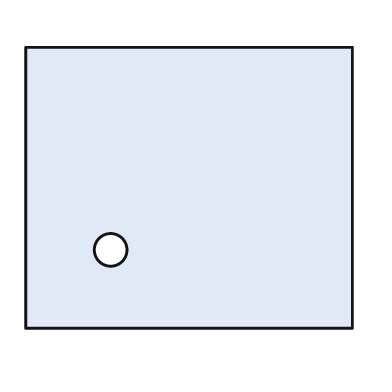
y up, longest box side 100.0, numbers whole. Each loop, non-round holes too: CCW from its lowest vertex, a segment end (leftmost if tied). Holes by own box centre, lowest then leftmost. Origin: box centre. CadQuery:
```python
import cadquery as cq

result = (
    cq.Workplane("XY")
    .moveTo(-50.0, -43.0)
    .lineTo(50.0, -43.0)
    .lineTo(50.0, 43.0)
    .lineTo(-50.0, 43.0)
    .close()
    .moveTo(-24.0, -19.0)
    .circle(5.0)
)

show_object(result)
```